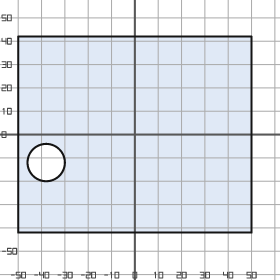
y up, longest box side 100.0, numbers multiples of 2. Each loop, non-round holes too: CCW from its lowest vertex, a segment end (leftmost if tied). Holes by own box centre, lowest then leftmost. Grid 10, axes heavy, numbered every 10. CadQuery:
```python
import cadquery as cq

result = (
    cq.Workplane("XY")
    .moveTo(-50.0, -42.0)
    .lineTo(50.0, -42.0)
    .lineTo(50.0, 42.0)
    .lineTo(-50.0, 42.0)
    .close()
    .moveTo(-38.0, -12.0)
    .circle(8.0)
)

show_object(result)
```